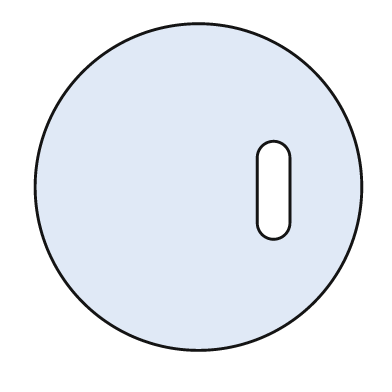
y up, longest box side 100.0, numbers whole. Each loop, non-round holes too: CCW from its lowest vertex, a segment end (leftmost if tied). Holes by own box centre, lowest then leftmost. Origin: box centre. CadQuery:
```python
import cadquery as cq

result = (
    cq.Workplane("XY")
    .moveTo(0.0, 0.0)
    .circle(50.0)
    .moveTo(18.0, -11.0)
    .threePointArc((23.0, -16.0), (28.0, -11.0))
    .lineTo(28.0, 9.0)
    .threePointArc((23.0, 14.0), (18.0, 9.0))
    .close()
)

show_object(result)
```